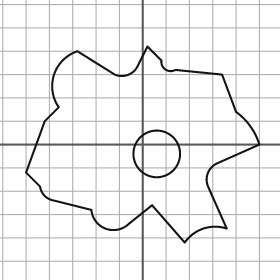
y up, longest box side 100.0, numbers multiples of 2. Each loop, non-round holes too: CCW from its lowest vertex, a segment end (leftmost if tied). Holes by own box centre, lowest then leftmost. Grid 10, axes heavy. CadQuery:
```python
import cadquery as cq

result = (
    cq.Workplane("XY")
    .moveTo(18.0, -42.0)
    .threePointArc((26.0, -36.0), (36.0, -36.0))
    .lineTo(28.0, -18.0)
    .threePointArc((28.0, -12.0), (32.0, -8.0))
    .lineTo(50.0, 0.0)
    .threePointArc((46.0, 8.0), (40.0, 14.0))
    .lineTo(34.0, 30.0)
    .lineTo(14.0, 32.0)
    .threePointArc((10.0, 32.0), (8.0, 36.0))
    .lineTo(2.0, 42.0)
    .lineTo(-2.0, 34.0)
    .threePointArc((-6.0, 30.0), (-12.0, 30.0))
    .lineTo(-28.0, 40.0)
    .threePointArc((-38.0, 30.0), (-36.0, 16.0))
    .lineTo(-42.0, 10.0)
    .lineTo(-50.0, -12.0)
    .lineTo(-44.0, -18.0)
    .threePointArc((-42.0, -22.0), (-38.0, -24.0))
    .lineTo(-22.0, -28.0)
    .threePointArc((-16.0, -36.0), (-6.0, -34.0))
    .lineTo(4.0, -26.0)
    .close()
    .moveTo(6.0, -4.0)
    .circle(10.0)
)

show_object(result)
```